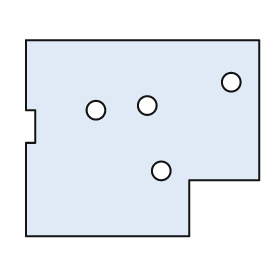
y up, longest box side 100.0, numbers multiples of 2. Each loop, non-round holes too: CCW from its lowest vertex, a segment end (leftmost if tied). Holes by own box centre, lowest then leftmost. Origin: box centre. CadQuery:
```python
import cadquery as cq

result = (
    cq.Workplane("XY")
    .moveTo(-50.0, -42.0)
    .lineTo(20.0, -42.0)
    .lineTo(20.0, -18.0)
    .lineTo(50.0, -18.0)
    .lineTo(50.0, 42.0)
    .lineTo(-50.0, 42.0)
    .lineTo(-50.0, 12.0)
    .lineTo(-46.0, 12.0)
    .lineTo(-46.0, -2.0)
    .lineTo(-50.0, -2.0)
    .close()
    .moveTo(8.0, -14.0)
    .circle(4.0)
    .moveTo(-20.0, 12.0)
    .circle(4.0)
    .moveTo(2.0, 14.0)
    .circle(4.0)
    .moveTo(38.0, 24.0)
    .circle(4.0)
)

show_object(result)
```